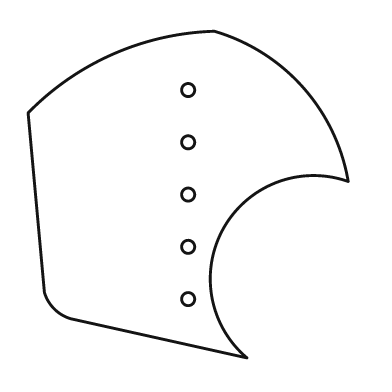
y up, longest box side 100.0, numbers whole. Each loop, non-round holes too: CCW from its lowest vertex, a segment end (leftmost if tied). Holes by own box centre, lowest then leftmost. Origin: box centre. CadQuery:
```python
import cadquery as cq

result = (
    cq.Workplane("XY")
    .moveTo(18.0, -50.0)
    .threePointArc((11.0, -10.0), (49.0, 4.0))
    .threePointArc((35.0, 33.0), (8.0, 50.0))
    .threePointArc((-23.0, 43.0), (-49.0, 25.0))
    .lineTo(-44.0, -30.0)
    .threePointArc((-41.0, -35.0), (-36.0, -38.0))
    .close()
    .moveTo(0.0, -32.0)
    .circle(2.0)
    .moveTo(0.0, -16.0)
    .circle(2.0)
    .moveTo(0.0, 0.0)
    .circle(2.0)
    .moveTo(0.0, 16.0)
    .circle(2.0)
    .moveTo(0.0, 32.0)
    .circle(2.0)
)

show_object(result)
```